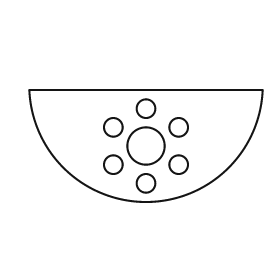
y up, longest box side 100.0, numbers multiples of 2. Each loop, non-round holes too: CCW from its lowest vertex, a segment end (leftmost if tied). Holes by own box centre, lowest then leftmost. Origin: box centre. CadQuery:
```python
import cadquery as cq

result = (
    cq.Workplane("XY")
    .moveTo(-50.0, 24.0)
    .threePointArc((0.0, -24.0), (50.0, 24.0))
    .close()
    .moveTo(0.0, -16.0)
    .circle(4.0)
    .moveTo(-14.0, -8.0)
    .circle(4.0)
    .moveTo(14.0, -8.0)
    .circle(4.0)
    .moveTo(0.0, 0.0)
    .circle(8.0)
    .moveTo(-14.0, 8.0)
    .circle(4.0)
    .moveTo(14.0, 8.0)
    .circle(4.0)
    .moveTo(0.0, 16.0)
    .circle(4.0)
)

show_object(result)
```